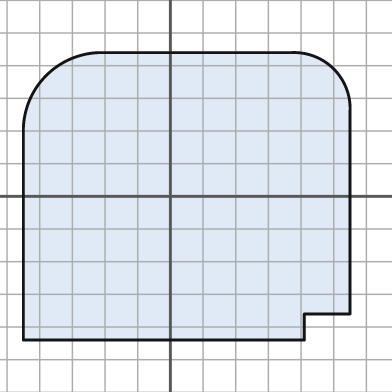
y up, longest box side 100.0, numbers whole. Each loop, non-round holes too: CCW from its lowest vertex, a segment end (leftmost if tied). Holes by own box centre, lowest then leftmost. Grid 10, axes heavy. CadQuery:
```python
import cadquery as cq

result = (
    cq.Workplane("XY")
    .moveTo(-45.0, -44.0)
    .lineTo(41.0, -44.0)
    .lineTo(41.0, -36.0)
    .lineTo(55.0, -36.0)
    .lineTo(55.0, 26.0)
    .threePointArc((50.0, 39.0), (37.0, 44.0))
    .lineTo(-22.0, 44.0)
    .threePointArc((-38.0, 37.0), (-45.0, 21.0))
    .close()
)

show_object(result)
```